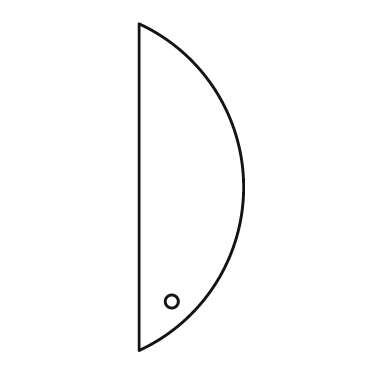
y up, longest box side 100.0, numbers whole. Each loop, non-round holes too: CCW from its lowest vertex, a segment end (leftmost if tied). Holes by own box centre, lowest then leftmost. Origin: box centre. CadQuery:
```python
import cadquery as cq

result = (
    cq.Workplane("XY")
    .moveTo(-16.0, -50.0)
    .threePointArc((16.0, 0.0), (-16.0, 50.0))
    .close()
    .moveTo(-6.0, -35.0)
    .circle(2.0)
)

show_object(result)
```